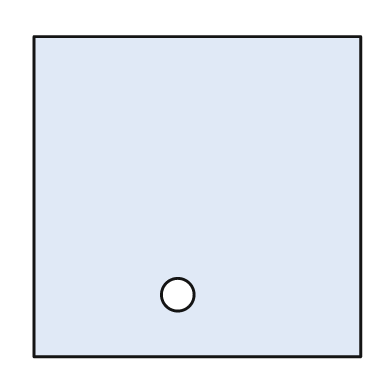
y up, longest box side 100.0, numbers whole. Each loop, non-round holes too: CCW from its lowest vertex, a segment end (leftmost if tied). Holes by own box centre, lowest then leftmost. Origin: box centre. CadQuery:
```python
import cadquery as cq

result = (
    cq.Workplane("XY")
    .moveTo(-50.0, -49.0)
    .lineTo(50.0, -49.0)
    .lineTo(50.0, 49.0)
    .lineTo(-50.0, 49.0)
    .close()
    .moveTo(-6.0, -30.0)
    .circle(5.0)
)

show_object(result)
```